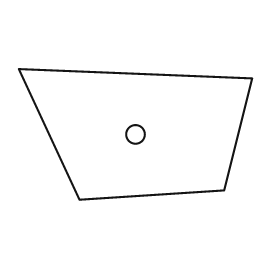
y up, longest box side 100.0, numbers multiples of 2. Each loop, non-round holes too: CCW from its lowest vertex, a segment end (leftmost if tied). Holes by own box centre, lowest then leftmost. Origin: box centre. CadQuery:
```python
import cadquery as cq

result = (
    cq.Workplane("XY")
    .moveTo(-24.0, -28.0)
    .lineTo(38.0, -24.0)
    .lineTo(50.0, 24.0)
    .lineTo(-50.0, 28.0)
    .close()
    .moveTo(0.0, 0.0)
    .circle(4.0)
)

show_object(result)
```